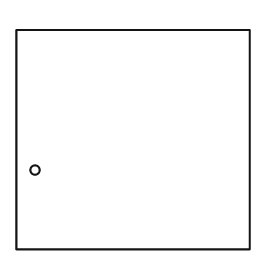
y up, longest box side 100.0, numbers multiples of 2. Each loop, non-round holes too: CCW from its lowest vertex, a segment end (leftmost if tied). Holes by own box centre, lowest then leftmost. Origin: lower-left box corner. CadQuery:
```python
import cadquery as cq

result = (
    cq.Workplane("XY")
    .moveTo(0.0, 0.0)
    .lineTo(100.0, 0.0)
    .lineTo(100.0, 94.0)
    .lineTo(0.0, 94.0)
    .close()
    .moveTo(8.0, 34.0)
    .circle(2.0)
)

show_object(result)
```